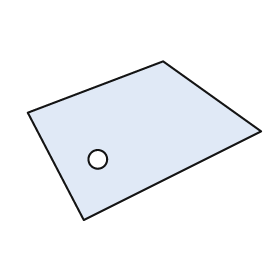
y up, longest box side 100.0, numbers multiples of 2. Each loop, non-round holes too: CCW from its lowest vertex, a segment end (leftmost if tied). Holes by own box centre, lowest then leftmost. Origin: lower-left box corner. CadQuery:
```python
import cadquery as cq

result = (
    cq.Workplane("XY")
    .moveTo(24.0, 0.0)
    .lineTo(100.0, 38.0)
    .lineTo(58.0, 68.0)
    .lineTo(0.0, 46.0)
    .close()
    .moveTo(30.0, 26.0)
    .circle(4.0)
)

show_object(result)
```